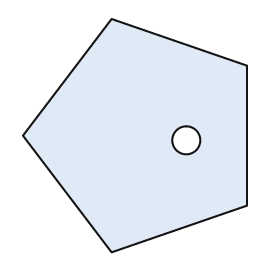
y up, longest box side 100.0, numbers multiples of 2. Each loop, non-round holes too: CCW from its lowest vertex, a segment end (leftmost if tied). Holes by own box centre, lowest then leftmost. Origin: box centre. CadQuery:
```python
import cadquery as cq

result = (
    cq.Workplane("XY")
    .moveTo(-10.0, -50.0)
    .lineTo(48.0, -30.0)
    .lineTo(48.0, 30.0)
    .lineTo(-10.0, 50.0)
    .lineTo(-48.0, 0.0)
    .close()
    .moveTo(22.0, -2.0)
    .circle(6.0)
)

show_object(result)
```